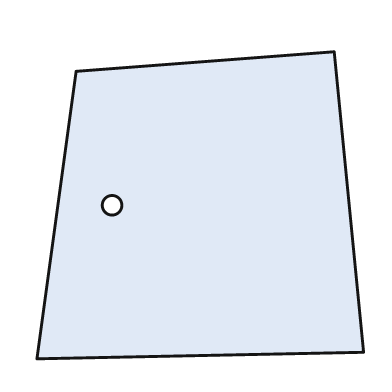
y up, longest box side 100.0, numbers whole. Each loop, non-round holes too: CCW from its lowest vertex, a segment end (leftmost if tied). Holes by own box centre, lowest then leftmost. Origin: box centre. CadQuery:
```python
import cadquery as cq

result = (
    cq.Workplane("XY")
    .moveTo(-50.0, -47.0)
    .lineTo(50.0, -45.0)
    .lineTo(41.0, 47.0)
    .lineTo(-38.0, 41.0)
    .close()
    .moveTo(-27.0, 0.0)
    .circle(3.0)
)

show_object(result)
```